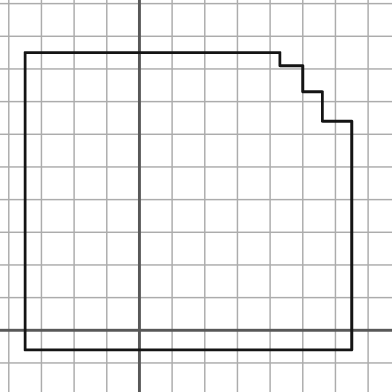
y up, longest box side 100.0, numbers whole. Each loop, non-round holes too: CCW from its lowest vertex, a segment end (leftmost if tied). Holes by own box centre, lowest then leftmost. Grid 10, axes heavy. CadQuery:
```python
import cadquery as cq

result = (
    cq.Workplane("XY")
    .moveTo(-35.0, -6.0)
    .lineTo(65.0, -6.0)
    .lineTo(65.0, 64.0)
    .lineTo(56.0, 64.0)
    .lineTo(56.0, 73.0)
    .lineTo(50.0, 73.0)
    .lineTo(50.0, 81.0)
    .lineTo(43.0, 81.0)
    .lineTo(43.0, 85.0)
    .lineTo(-35.0, 85.0)
    .close()
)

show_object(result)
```